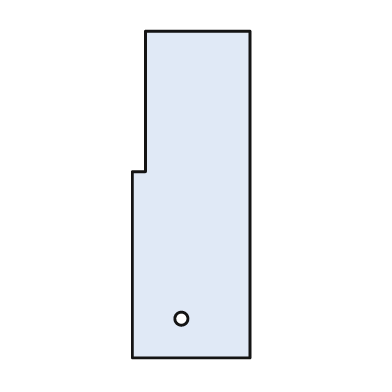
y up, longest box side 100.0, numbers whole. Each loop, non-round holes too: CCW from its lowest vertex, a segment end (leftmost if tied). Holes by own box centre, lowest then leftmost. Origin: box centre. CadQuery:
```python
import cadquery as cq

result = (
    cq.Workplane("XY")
    .moveTo(-18.0, -50.0)
    .lineTo(18.0, -50.0)
    .lineTo(18.0, 50.0)
    .lineTo(-14.0, 50.0)
    .lineTo(-14.0, 7.0)
    .lineTo(-18.0, 7.0)
    .close()
    .moveTo(-3.0, -38.0)
    .circle(2.0)
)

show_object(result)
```